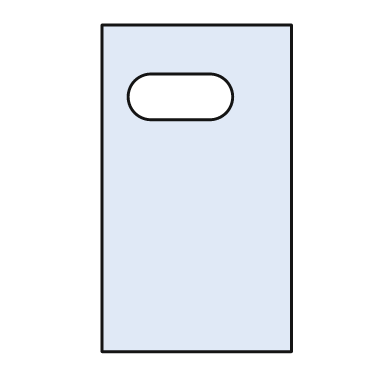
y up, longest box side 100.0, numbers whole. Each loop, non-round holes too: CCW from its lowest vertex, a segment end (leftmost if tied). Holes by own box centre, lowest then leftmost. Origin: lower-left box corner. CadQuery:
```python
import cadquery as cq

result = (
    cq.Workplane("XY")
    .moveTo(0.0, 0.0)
    .lineTo(58.0, 0.0)
    .lineTo(58.0, 100.0)
    .lineTo(0.0, 100.0)
    .close()
    .moveTo(15.0, 71.0)
    .lineTo(33.0, 71.0)
    .threePointArc((40.0, 78.0), (33.0, 85.0))
    .lineTo(15.0, 85.0)
    .threePointArc((8.0, 78.0), (15.0, 71.0))
    .close()
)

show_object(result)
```